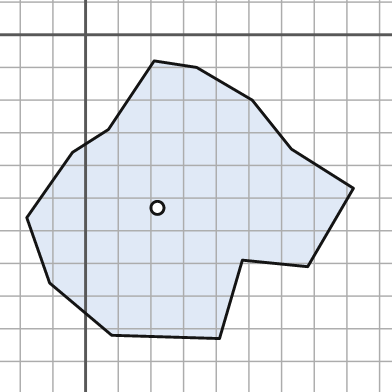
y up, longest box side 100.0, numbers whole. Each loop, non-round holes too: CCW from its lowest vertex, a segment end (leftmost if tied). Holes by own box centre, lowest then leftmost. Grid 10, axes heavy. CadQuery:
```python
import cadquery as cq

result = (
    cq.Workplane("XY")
    .moveTo(41.0, -93.0)
    .lineTo(48.0, -69.0)
    .lineTo(68.0, -71.0)
    .lineTo(82.0, -47.0)
    .lineTo(63.0, -35.0)
    .lineTo(51.0, -20.0)
    .lineTo(34.0, -10.0)
    .lineTo(21.0, -8.0)
    .lineTo(7.0, -29.0)
    .lineTo(-4.0, -36.0)
    .lineTo(-18.0, -56.0)
    .lineTo(-11.0, -76.0)
    .lineTo(8.0, -92.0)
    .close()
    .moveTo(22.0, -53.0)
    .circle(2.0)
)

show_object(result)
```